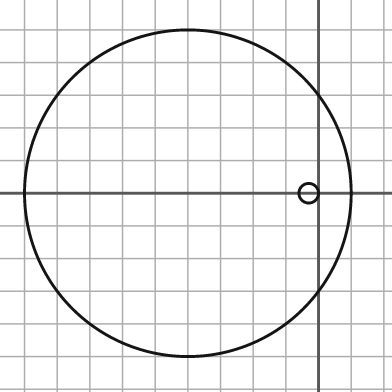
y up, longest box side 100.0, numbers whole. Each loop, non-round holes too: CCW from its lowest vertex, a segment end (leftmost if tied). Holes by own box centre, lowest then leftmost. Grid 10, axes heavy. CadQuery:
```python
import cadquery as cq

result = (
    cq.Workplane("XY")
    .moveTo(-40.0, 0.0)
    .circle(50.0)
    .moveTo(-3.0, 0.0)
    .circle(3.0)
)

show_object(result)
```